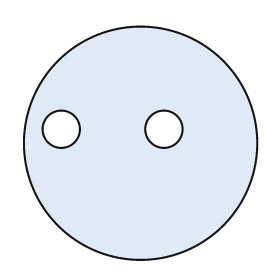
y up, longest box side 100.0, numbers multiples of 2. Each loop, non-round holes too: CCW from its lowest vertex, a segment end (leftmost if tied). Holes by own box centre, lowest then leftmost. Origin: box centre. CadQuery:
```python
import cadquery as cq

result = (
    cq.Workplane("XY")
    .moveTo(0.0, 0.0)
    .circle(50.0)
    .moveTo(-34.0, 6.0)
    .circle(8.0)
    .moveTo(10.0, 6.0)
    .circle(8.0)
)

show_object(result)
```